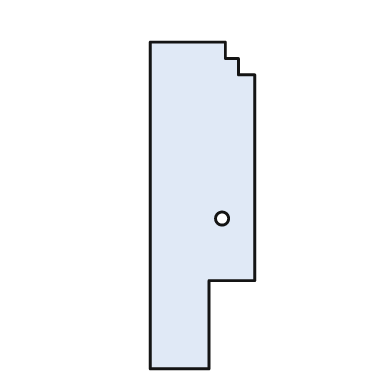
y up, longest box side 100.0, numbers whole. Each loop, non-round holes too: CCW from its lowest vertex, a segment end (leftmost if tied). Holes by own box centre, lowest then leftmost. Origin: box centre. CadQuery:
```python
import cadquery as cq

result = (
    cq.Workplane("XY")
    .moveTo(-16.0, -50.0)
    .lineTo(2.0, -50.0)
    .lineTo(2.0, -23.0)
    .lineTo(16.0, -23.0)
    .lineTo(16.0, 40.0)
    .lineTo(11.0, 40.0)
    .lineTo(11.0, 45.0)
    .lineTo(7.0, 45.0)
    .lineTo(7.0, 50.0)
    .lineTo(-16.0, 50.0)
    .close()
    .moveTo(6.0, -4.0)
    .circle(2.0)
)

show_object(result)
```